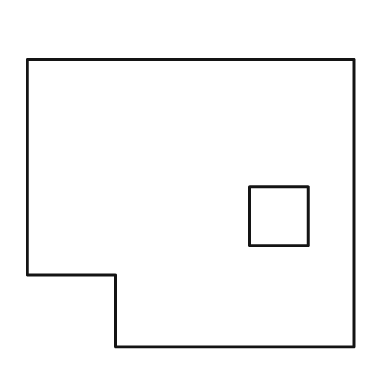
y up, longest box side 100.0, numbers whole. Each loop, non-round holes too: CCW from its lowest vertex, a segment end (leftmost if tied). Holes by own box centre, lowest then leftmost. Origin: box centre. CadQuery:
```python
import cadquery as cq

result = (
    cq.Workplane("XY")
    .moveTo(-23.0, -44.0)
    .lineTo(50.0, -44.0)
    .lineTo(50.0, 44.0)
    .lineTo(-50.0, 44.0)
    .lineTo(-50.0, -22.0)
    .lineTo(-23.0, -22.0)
    .close()
    .moveTo(18.0, -13.0)
    .lineTo(36.0, -13.0)
    .lineTo(36.0, 5.0)
    .lineTo(18.0, 5.0)
    .close()
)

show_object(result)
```